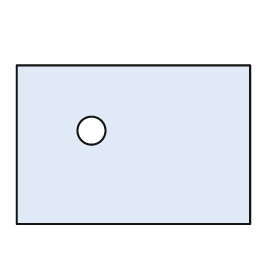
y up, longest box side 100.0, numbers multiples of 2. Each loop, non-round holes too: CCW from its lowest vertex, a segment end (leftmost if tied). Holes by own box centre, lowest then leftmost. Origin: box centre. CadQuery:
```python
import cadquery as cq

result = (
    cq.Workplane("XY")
    .moveTo(-50.0, -34.0)
    .lineTo(50.0, -34.0)
    .lineTo(50.0, 34.0)
    .lineTo(-50.0, 34.0)
    .close()
    .moveTo(-18.0, 6.0)
    .circle(6.0)
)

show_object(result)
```